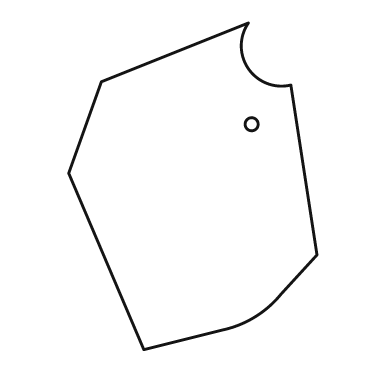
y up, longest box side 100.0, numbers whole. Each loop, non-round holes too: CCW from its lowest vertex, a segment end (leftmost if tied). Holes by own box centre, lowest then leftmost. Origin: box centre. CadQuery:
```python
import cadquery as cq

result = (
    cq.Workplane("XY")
    .moveTo(-15.0, -50.0)
    .lineTo(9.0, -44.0)
    .threePointArc((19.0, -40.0), (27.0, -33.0))
    .lineTo(38.0, -21.0)
    .lineTo(30.0, 31.0)
    .threePointArc((17.0, 36.0), (17.0, 50.0))
    .lineTo(-28.0, 32.0)
    .lineTo(-38.0, 4.0)
    .close()
    .moveTo(18.0, 19.0)
    .circle(2.0)
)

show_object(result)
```